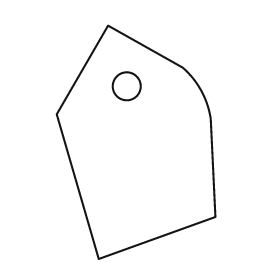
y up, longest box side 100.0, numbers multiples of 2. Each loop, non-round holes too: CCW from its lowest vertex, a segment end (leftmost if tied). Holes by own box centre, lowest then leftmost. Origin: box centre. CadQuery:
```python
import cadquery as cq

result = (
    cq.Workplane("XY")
    .moveTo(-16.0, -50.0)
    .lineTo(34.0, -32.0)
    .lineTo(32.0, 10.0)
    .threePointArc((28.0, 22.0), (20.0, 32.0))
    .lineTo(-12.0, 50.0)
    .lineTo(-34.0, 12.0)
    .close()
    .moveTo(-4.0, 24.0)
    .circle(6.0)
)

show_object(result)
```